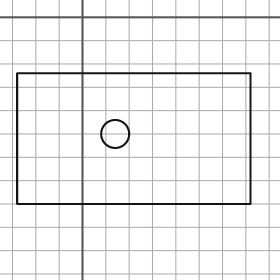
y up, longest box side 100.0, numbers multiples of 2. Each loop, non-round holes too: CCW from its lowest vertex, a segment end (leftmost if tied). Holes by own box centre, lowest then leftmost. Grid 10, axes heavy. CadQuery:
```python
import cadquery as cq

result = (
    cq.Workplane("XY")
    .moveTo(-28.0, -80.0)
    .lineTo(72.0, -80.0)
    .lineTo(72.0, -24.0)
    .lineTo(-28.0, -24.0)
    .close()
    .moveTo(14.0, -50.0)
    .circle(6.0)
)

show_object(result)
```